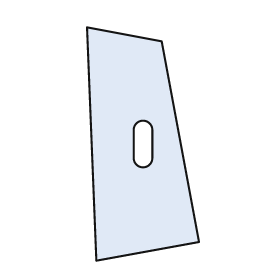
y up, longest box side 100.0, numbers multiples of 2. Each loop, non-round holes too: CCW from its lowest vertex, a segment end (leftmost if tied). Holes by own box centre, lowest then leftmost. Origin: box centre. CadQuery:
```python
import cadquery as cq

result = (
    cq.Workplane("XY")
    .moveTo(-20.0, -50.0)
    .lineTo(24.0, -42.0)
    .lineTo(8.0, 44.0)
    .lineTo(-24.0, 50.0)
    .close()
    .moveTo(-4.0, -6.0)
    .threePointArc((0.0, -10.0), (4.0, -6.0))
    .lineTo(4.0, 6.0)
    .threePointArc((0.0, 10.0), (-4.0, 6.0))
    .close()
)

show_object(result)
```